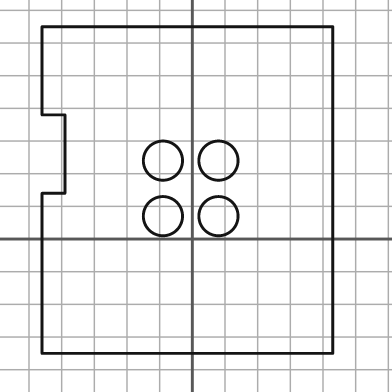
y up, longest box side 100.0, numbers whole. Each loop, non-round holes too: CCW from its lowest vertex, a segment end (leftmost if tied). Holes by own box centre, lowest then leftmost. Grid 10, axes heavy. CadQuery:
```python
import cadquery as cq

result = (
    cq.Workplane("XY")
    .moveTo(-46.0, -35.0)
    .lineTo(43.0, -35.0)
    .lineTo(43.0, 65.0)
    .lineTo(-46.0, 65.0)
    .lineTo(-46.0, 38.0)
    .lineTo(-39.0, 38.0)
    .lineTo(-39.0, 14.0)
    .lineTo(-46.0, 14.0)
    .close()
    .moveTo(-9.0, 7.0)
    .circle(6.0)
    .moveTo(8.0, 7.0)
    .circle(6.0)
    .moveTo(-9.0, 24.0)
    .circle(6.0)
    .moveTo(8.0, 24.0)
    .circle(6.0)
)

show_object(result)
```